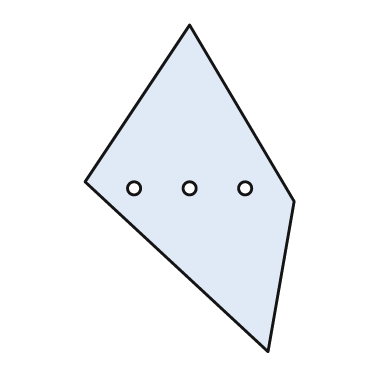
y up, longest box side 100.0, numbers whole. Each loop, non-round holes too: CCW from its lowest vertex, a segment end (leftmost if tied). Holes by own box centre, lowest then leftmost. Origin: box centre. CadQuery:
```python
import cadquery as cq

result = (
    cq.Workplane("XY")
    .moveTo(24.0, -50.0)
    .lineTo(32.0, -4.0)
    .lineTo(0.0, 50.0)
    .lineTo(-32.0, 2.0)
    .close()
    .moveTo(-17.0, 0.0)
    .circle(2.0)
    .moveTo(0.0, 0.0)
    .circle(2.0)
    .moveTo(17.0, 0.0)
    .circle(2.0)
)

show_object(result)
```